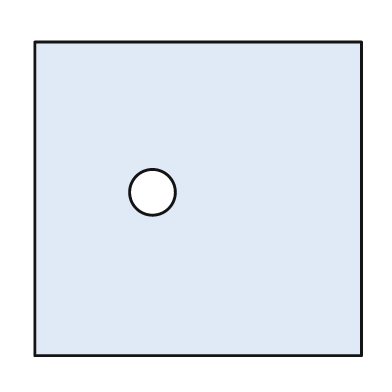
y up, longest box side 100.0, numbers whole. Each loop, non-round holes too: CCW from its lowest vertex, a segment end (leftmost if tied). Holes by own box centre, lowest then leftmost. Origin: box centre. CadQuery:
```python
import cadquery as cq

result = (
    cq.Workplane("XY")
    .moveTo(-50.0, -48.0)
    .lineTo(50.0, -48.0)
    .lineTo(50.0, 48.0)
    .lineTo(-50.0, 48.0)
    .close()
    .moveTo(-14.0, 2.0)
    .circle(7.0)
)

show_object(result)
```